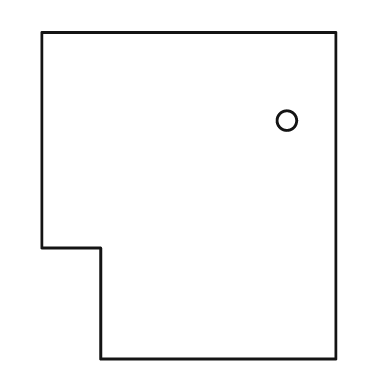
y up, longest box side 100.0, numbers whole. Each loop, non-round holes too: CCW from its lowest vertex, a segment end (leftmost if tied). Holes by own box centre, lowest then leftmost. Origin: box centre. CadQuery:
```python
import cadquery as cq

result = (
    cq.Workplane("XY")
    .moveTo(-27.0, -50.0)
    .lineTo(45.0, -50.0)
    .lineTo(45.0, 50.0)
    .lineTo(-45.0, 50.0)
    .lineTo(-45.0, -16.0)
    .lineTo(-27.0, -16.0)
    .close()
    .moveTo(30.0, 23.0)
    .circle(3.0)
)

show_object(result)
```